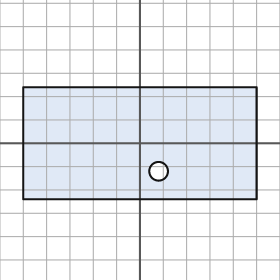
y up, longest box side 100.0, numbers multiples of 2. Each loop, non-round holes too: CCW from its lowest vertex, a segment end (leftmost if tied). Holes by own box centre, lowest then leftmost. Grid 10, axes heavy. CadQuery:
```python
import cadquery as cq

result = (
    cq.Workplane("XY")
    .moveTo(-50.0, -24.0)
    .lineTo(50.0, -24.0)
    .lineTo(50.0, 24.0)
    .lineTo(-50.0, 24.0)
    .close()
    .moveTo(8.0, -12.0)
    .circle(4.0)
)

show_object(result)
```